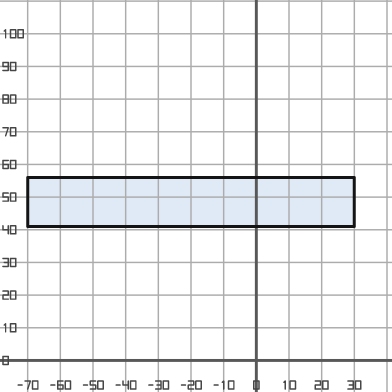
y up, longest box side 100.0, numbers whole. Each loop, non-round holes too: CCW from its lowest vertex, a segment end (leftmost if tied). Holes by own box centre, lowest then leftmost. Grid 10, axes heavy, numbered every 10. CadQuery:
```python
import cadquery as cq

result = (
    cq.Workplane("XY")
    .moveTo(-70.0, 41.0)
    .lineTo(30.0, 41.0)
    .lineTo(30.0, 56.0)
    .lineTo(-70.0, 56.0)
    .close()
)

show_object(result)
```